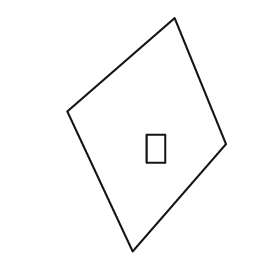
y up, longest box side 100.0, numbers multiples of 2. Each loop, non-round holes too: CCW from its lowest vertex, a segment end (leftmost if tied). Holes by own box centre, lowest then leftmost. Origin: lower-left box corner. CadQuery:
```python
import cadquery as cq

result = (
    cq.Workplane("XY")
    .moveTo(28.0, 0.0)
    .lineTo(68.0, 46.0)
    .lineTo(46.0, 100.0)
    .lineTo(0.0, 60.0)
    .close()
    .moveTo(34.0, 38.0)
    .lineTo(42.0, 38.0)
    .lineTo(42.0, 50.0)
    .lineTo(34.0, 50.0)
    .close()
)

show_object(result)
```